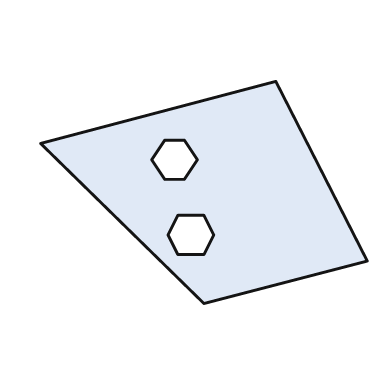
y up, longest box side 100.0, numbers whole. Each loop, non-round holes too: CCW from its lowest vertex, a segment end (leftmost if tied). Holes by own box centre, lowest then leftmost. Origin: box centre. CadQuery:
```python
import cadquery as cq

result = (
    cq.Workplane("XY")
    .moveTo(0.0, -34.0)
    .lineTo(50.0, -21.0)
    .lineTo(22.0, 34.0)
    .lineTo(-50.0, 15.0)
    .close()
    .moveTo(-8.0, -19.0)
    .lineTo(0.0, -19.0)
    .lineTo(3.0, -13.0)
    .lineTo(0.0, -7.0)
    .lineTo(-8.0, -7.0)
    .lineTo(-11.0, -13.0)
    .close()
    .moveTo(-12.0, 4.0)
    .lineTo(-6.0, 4.0)
    .lineTo(-2.0, 10.0)
    .lineTo(-6.0, 16.0)
    .lineTo(-12.0, 16.0)
    .lineTo(-16.0, 10.0)
    .close()
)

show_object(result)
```